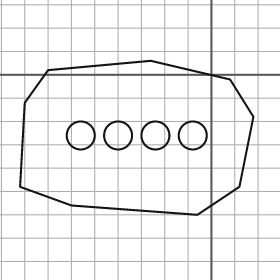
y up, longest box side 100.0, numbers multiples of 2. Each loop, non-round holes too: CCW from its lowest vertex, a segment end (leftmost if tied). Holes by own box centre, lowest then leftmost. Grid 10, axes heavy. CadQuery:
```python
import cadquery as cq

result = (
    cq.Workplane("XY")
    .moveTo(-6.0, -60.0)
    .lineTo(12.0, -48.0)
    .lineTo(18.0, -18.0)
    .lineTo(8.0, -2.0)
    .lineTo(-26.0, 6.0)
    .lineTo(-70.0, 2.0)
    .lineTo(-80.0, -12.0)
    .lineTo(-82.0, -48.0)
    .lineTo(-60.0, -56.0)
    .close()
    .moveTo(-56.0, -26.0)
    .circle(6.0)
    .moveTo(-40.0, -26.0)
    .circle(6.0)
    .moveTo(-24.0, -26.0)
    .circle(6.0)
    .moveTo(-8.0, -26.0)
    .circle(6.0)
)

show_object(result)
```